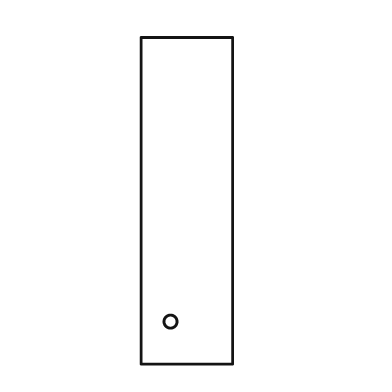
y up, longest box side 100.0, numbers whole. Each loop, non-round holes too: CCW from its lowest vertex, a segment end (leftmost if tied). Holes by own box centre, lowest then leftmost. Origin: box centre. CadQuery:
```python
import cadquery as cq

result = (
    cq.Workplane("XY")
    .moveTo(-14.0, -50.0)
    .lineTo(14.0, -50.0)
    .lineTo(14.0, 50.0)
    .lineTo(-14.0, 50.0)
    .close()
    .moveTo(-5.0, -37.0)
    .circle(2.0)
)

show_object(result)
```